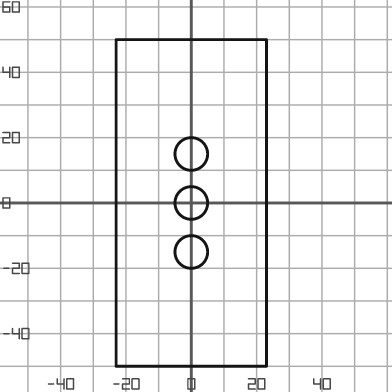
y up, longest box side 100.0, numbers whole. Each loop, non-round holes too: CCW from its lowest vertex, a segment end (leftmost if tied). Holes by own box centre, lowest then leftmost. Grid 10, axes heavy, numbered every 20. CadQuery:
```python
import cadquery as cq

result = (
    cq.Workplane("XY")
    .moveTo(-23.0, -50.0)
    .lineTo(23.0, -50.0)
    .lineTo(23.0, 50.0)
    .lineTo(-23.0, 50.0)
    .close()
    .moveTo(0.0, -15.0)
    .circle(5.0)
    .moveTo(0.0, 0.0)
    .circle(5.0)
    .moveTo(0.0, 15.0)
    .circle(5.0)
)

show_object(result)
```